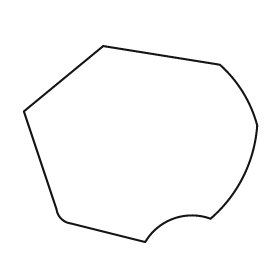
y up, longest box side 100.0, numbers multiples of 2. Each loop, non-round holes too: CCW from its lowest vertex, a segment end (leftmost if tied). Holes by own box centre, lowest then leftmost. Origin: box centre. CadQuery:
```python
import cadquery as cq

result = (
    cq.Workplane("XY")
    .moveTo(2.0, -42.0)
    .threePointArc((14.0, -32.0), (30.0, -32.0))
    .threePointArc((44.0, -14.0), (50.0, 8.0))
    .threePointArc((44.0, 22.0), (34.0, 34.0))
    .lineTo(-16.0, 42.0)
    .lineTo(-50.0, 14.0)
    .lineTo(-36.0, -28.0)
    .threePointArc((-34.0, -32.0), (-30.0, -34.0))
    .close()
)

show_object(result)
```